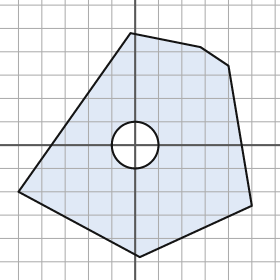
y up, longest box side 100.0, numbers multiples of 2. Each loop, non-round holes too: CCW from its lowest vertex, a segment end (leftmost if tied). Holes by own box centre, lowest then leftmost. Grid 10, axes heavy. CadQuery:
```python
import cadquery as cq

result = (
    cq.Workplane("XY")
    .moveTo(2.0, -48.0)
    .lineTo(50.0, -26.0)
    .lineTo(40.0, 34.0)
    .lineTo(28.0, 42.0)
    .lineTo(-2.0, 48.0)
    .lineTo(-50.0, -20.0)
    .close()
    .moveTo(0.0, 0.0)
    .circle(10.0)
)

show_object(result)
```